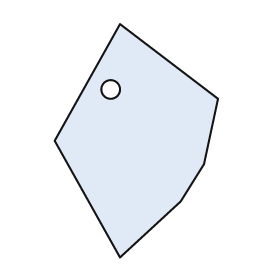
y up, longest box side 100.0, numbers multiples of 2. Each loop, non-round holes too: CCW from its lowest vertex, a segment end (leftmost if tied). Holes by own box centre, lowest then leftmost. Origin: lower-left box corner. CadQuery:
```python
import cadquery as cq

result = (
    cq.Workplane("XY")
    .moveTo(28.0, 0.0)
    .lineTo(54.0, 24.0)
    .lineTo(64.0, 40.0)
    .lineTo(70.0, 68.0)
    .lineTo(28.0, 100.0)
    .lineTo(0.0, 50.0)
    .close()
    .moveTo(24.0, 72.0)
    .circle(4.0)
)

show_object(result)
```